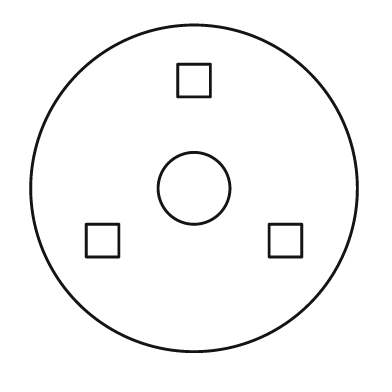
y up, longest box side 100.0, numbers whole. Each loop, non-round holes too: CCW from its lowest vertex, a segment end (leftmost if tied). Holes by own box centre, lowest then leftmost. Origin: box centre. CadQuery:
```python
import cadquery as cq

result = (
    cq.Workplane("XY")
    .moveTo(0.0, 0.0)
    .circle(50.0)
    .moveTo(-33.0, -21.0)
    .lineTo(-23.0, -21.0)
    .lineTo(-23.0, -11.0)
    .lineTo(-33.0, -11.0)
    .close()
    .moveTo(23.0, -21.0)
    .lineTo(33.0, -21.0)
    .lineTo(33.0, -11.0)
    .lineTo(23.0, -11.0)
    .close()
    .moveTo(0.0, 0.0)
    .circle(11.0)
    .moveTo(-5.0, 28.0)
    .lineTo(5.0, 28.0)
    .lineTo(5.0, 38.0)
    .lineTo(-5.0, 38.0)
    .close()
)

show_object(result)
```